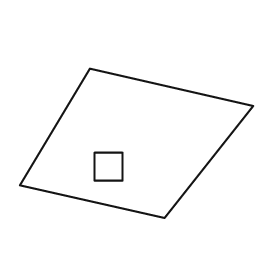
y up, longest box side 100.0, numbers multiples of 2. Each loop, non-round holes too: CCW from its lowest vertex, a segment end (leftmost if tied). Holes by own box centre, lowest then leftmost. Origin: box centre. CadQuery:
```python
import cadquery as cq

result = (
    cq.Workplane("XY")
    .moveTo(12.0, -32.0)
    .lineTo(50.0, 16.0)
    .lineTo(-20.0, 32.0)
    .lineTo(-50.0, -18.0)
    .close()
    .moveTo(-18.0, -16.0)
    .lineTo(-6.0, -16.0)
    .lineTo(-6.0, -4.0)
    .lineTo(-18.0, -4.0)
    .close()
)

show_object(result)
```